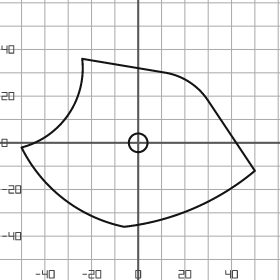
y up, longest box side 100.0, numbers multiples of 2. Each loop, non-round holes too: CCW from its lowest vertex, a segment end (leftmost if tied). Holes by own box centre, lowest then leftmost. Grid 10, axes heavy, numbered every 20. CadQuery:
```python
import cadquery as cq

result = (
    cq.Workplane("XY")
    .moveTo(-6.0, -36.0)
    .threePointArc((24.0, -28.0), (50.0, -12.0))
    .lineTo(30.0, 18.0)
    .threePointArc((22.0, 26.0), (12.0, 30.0))
    .lineTo(-24.0, 36.0)
    .threePointArc((-30.0, 12.0), (-50.0, -2.0))
    .threePointArc((-32.0, -24.0), (-6.0, -36.0))
    .close()
    .moveTo(0.0, 0.0)
    .circle(4.0)
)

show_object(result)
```